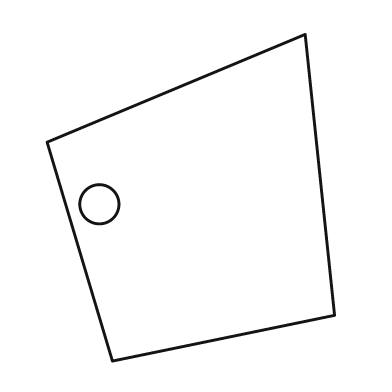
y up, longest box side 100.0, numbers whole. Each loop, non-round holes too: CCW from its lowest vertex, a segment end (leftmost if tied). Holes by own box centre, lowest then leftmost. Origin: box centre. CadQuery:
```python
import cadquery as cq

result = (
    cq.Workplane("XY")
    .moveTo(-24.0, -50.0)
    .lineTo(44.0, -36.0)
    .lineTo(35.0, 50.0)
    .lineTo(-44.0, 17.0)
    .close()
    .moveTo(-28.0, -2.0)
    .circle(6.0)
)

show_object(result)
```